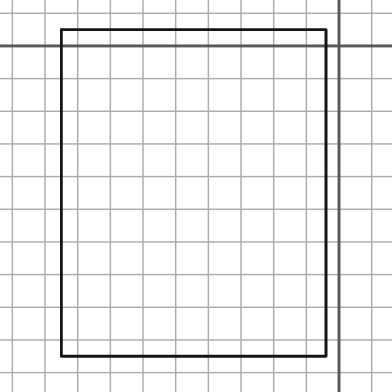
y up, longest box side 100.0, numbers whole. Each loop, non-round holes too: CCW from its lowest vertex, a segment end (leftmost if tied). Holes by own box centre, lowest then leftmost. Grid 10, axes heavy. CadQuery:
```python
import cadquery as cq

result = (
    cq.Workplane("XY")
    .moveTo(-85.0, -95.0)
    .lineTo(-4.0, -95.0)
    .lineTo(-4.0, 5.0)
    .lineTo(-85.0, 5.0)
    .close()
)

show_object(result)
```